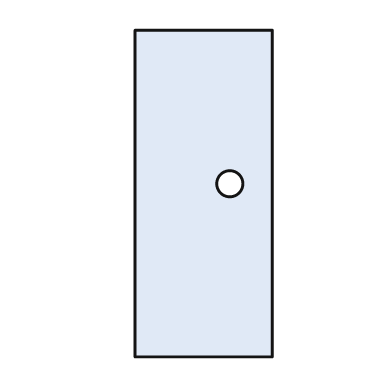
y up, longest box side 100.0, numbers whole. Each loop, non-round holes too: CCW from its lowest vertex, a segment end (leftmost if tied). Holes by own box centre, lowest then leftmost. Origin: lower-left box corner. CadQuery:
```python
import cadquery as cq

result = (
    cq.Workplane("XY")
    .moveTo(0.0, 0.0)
    .lineTo(42.0, 0.0)
    .lineTo(42.0, 100.0)
    .lineTo(0.0, 100.0)
    .close()
    .moveTo(29.0, 53.0)
    .circle(4.0)
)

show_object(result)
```